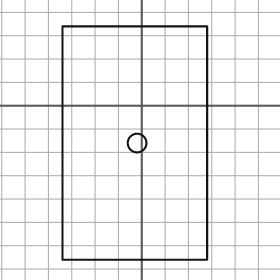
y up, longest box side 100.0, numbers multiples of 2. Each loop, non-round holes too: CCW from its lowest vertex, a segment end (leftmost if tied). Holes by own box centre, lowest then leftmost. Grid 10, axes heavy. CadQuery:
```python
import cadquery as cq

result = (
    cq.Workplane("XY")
    .moveTo(-34.0, -66.0)
    .lineTo(28.0, -66.0)
    .lineTo(28.0, 34.0)
    .lineTo(-34.0, 34.0)
    .close()
    .moveTo(-2.0, -16.0)
    .circle(4.0)
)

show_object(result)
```